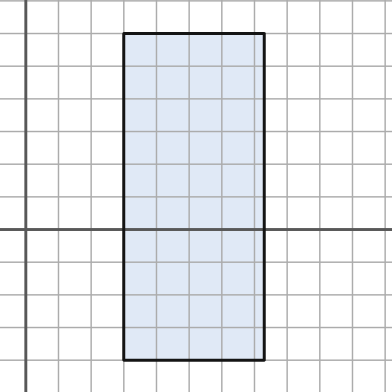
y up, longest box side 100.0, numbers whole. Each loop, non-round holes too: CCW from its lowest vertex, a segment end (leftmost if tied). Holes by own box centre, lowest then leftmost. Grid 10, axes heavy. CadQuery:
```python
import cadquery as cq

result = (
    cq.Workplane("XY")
    .moveTo(30.0, -40.0)
    .lineTo(73.0, -40.0)
    .lineTo(73.0, 60.0)
    .lineTo(30.0, 60.0)
    .close()
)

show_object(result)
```